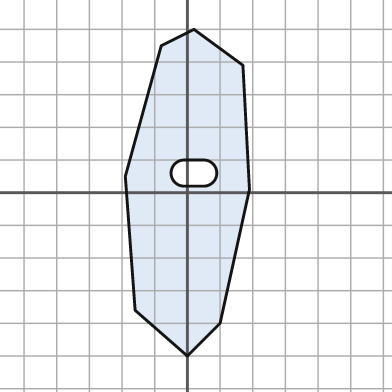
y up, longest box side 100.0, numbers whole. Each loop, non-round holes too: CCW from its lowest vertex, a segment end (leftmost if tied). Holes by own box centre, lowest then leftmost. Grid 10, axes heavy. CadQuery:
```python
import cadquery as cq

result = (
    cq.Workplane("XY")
    .moveTo(0.0, -50.0)
    .lineTo(10.0, -40.0)
    .lineTo(19.0, 1.0)
    .lineTo(17.0, 39.0)
    .lineTo(2.0, 50.0)
    .lineTo(-8.0, 45.0)
    .lineTo(-19.0, 5.0)
    .lineTo(-16.0, -36.0)
    .close()
    .moveTo(-1.0, 2.0)
    .lineTo(5.0, 2.0)
    .threePointArc((9.0, 6.0), (5.0, 10.0))
    .lineTo(-1.0, 10.0)
    .threePointArc((-5.0, 6.0), (-1.0, 2.0))
    .close()
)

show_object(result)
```